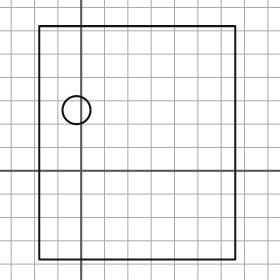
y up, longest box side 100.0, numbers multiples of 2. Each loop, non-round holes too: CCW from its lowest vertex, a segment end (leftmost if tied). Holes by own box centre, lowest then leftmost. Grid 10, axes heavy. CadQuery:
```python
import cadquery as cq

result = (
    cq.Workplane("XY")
    .moveTo(-18.0, -38.0)
    .lineTo(66.0, -38.0)
    .lineTo(66.0, 62.0)
    .lineTo(-18.0, 62.0)
    .close()
    .moveTo(-2.0, 26.0)
    .circle(6.0)
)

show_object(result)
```